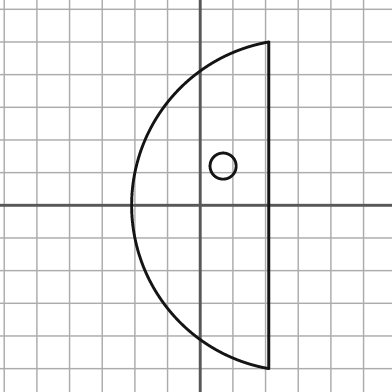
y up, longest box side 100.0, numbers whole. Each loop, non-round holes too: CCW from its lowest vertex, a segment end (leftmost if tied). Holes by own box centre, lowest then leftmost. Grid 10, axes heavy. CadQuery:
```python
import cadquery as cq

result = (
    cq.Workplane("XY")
    .moveTo(21.0, -50.0)
    .lineTo(21.0, 50.0)
    .threePointArc((-21.0, 0.0), (21.0, -50.0))
    .close()
    .moveTo(7.0, 12.0)
    .circle(4.0)
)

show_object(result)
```